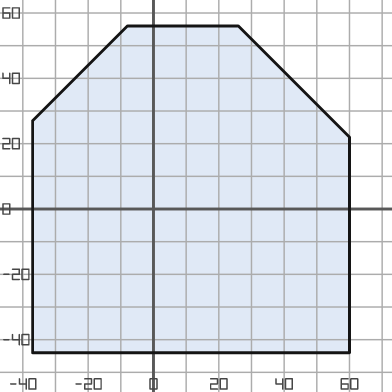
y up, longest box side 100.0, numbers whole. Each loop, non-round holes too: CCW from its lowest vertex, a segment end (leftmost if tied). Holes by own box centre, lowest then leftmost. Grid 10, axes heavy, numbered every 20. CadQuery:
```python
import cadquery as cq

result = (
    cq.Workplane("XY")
    .moveTo(-37.0, -44.0)
    .lineTo(60.0, -44.0)
    .lineTo(60.0, 22.0)
    .lineTo(26.0, 56.0)
    .lineTo(-8.0, 56.0)
    .lineTo(-37.0, 27.0)
    .close()
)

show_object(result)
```